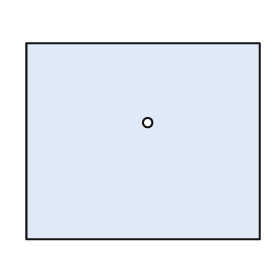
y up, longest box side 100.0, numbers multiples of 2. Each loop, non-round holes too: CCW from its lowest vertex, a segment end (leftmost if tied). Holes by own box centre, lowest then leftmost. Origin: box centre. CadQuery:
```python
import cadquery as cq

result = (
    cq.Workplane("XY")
    .moveTo(-50.0, -42.0)
    .lineTo(50.0, -42.0)
    .lineTo(50.0, 42.0)
    .lineTo(-50.0, 42.0)
    .close()
    .moveTo(2.0, 8.0)
    .circle(2.0)
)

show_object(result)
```